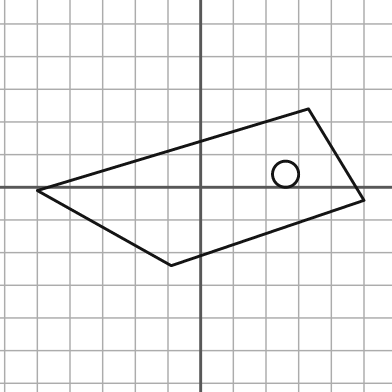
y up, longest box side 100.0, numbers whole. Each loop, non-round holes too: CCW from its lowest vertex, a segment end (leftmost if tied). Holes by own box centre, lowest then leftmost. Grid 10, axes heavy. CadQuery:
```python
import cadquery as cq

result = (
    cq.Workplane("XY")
    .moveTo(-9.0, -24.0)
    .lineTo(50.0, -4.0)
    .lineTo(33.0, 24.0)
    .lineTo(-50.0, -1.0)
    .close()
    .moveTo(26.0, 4.0)
    .circle(4.0)
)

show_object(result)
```